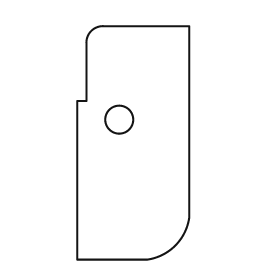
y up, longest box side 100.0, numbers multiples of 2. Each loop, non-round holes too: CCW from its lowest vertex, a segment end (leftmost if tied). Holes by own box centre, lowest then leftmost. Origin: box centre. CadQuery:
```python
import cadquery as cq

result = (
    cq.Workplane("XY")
    .moveTo(-24.0, -50.0)
    .lineTo(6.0, -50.0)
    .threePointArc((18.0, -44.0), (24.0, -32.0))
    .lineTo(24.0, 50.0)
    .lineTo(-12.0, 50.0)
    .threePointArc((-18.0, 48.0), (-20.0, 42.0))
    .lineTo(-20.0, 18.0)
    .lineTo(-24.0, 18.0)
    .close()
    .moveTo(-6.0, 10.0)
    .circle(6.0)
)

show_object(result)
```